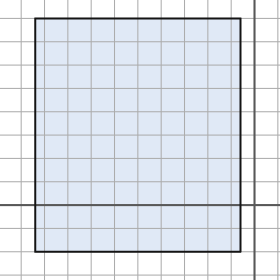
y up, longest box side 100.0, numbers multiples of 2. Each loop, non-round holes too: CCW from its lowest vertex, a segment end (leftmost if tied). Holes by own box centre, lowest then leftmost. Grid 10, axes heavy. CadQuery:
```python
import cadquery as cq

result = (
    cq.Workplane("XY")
    .moveTo(-94.0, -20.0)
    .lineTo(-6.0, -20.0)
    .lineTo(-6.0, 80.0)
    .lineTo(-94.0, 80.0)
    .close()
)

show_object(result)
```